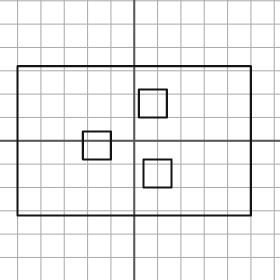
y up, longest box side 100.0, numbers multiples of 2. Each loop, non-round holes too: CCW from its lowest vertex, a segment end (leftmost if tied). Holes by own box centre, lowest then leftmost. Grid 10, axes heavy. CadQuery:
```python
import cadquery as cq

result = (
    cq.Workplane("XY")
    .moveTo(-50.0, -32.0)
    .lineTo(50.0, -32.0)
    .lineTo(50.0, 32.0)
    .lineTo(-50.0, 32.0)
    .close()
    .moveTo(4.0, -20.0)
    .lineTo(16.0, -20.0)
    .lineTo(16.0, -8.0)
    .lineTo(4.0, -8.0)
    .close()
    .moveTo(-22.0, -8.0)
    .lineTo(-10.0, -8.0)
    .lineTo(-10.0, 4.0)
    .lineTo(-22.0, 4.0)
    .close()
    .moveTo(2.0, 10.0)
    .lineTo(14.0, 10.0)
    .lineTo(14.0, 22.0)
    .lineTo(2.0, 22.0)
    .close()
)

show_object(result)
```